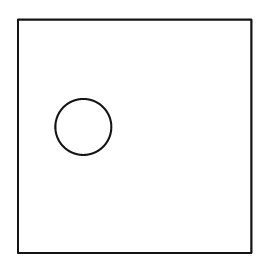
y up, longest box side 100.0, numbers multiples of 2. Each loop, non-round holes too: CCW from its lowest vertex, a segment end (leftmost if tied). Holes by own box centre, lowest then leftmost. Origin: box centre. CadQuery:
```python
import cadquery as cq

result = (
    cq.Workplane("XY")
    .moveTo(-50.0, -50.0)
    .lineTo(50.0, -50.0)
    .lineTo(50.0, 50.0)
    .lineTo(-50.0, 50.0)
    .close()
    .moveTo(-22.0, 4.0)
    .circle(12.0)
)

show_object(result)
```